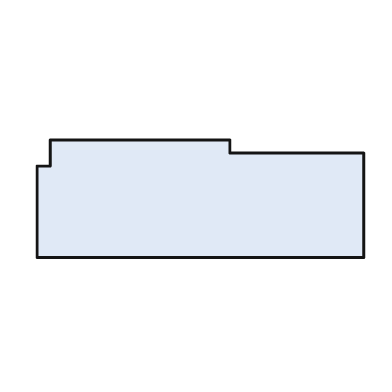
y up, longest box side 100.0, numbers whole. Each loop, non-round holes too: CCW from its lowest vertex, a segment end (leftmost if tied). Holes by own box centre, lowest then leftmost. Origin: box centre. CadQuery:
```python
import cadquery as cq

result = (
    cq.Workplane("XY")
    .moveTo(-50.0, -18.0)
    .lineTo(50.0, -18.0)
    .lineTo(50.0, 14.0)
    .lineTo(9.0, 14.0)
    .lineTo(9.0, 18.0)
    .lineTo(-46.0, 18.0)
    .lineTo(-46.0, 10.0)
    .lineTo(-50.0, 10.0)
    .close()
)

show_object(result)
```